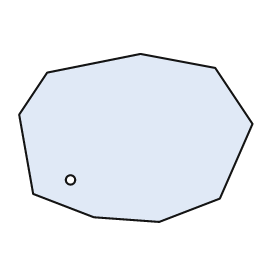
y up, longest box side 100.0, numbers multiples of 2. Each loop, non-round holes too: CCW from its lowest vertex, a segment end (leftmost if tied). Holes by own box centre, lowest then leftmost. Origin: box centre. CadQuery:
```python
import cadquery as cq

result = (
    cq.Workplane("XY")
    .moveTo(10.0, -36.0)
    .lineTo(36.0, -26.0)
    .lineTo(50.0, 6.0)
    .lineTo(34.0, 30.0)
    .lineTo(2.0, 36.0)
    .lineTo(-38.0, 28.0)
    .lineTo(-50.0, 10.0)
    .lineTo(-44.0, -24.0)
    .lineTo(-18.0, -34.0)
    .close()
    .moveTo(-28.0, -18.0)
    .circle(2.0)
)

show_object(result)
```